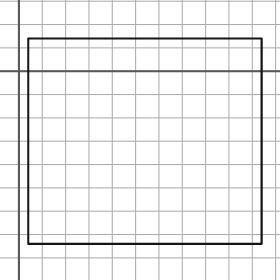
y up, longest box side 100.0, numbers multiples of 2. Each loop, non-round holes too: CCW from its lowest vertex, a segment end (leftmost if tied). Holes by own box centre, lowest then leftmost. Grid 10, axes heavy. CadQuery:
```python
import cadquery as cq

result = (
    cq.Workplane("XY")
    .moveTo(4.0, -74.0)
    .lineTo(104.0, -74.0)
    .lineTo(104.0, 14.0)
    .lineTo(4.0, 14.0)
    .close()
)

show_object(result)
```